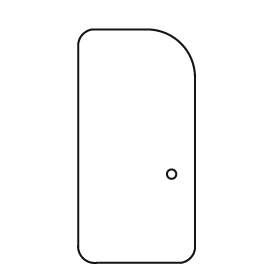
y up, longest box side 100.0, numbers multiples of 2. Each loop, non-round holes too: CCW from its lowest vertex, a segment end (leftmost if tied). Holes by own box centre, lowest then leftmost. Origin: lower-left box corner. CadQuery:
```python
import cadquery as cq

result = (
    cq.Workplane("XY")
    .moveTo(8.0, 0.0)
    .lineTo(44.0, 0.0)
    .threePointArc((48.0, 2.0), (50.0, 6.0))
    .lineTo(50.0, 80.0)
    .threePointArc((44.0, 94.0), (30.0, 100.0))
    .lineTo(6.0, 100.0)
    .threePointArc((2.0, 98.0), (0.0, 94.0))
    .lineTo(0.0, 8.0)
    .threePointArc((2.0, 2.0), (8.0, 0.0))
    .close()
    .moveTo(40.0, 38.0)
    .circle(2.0)
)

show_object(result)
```